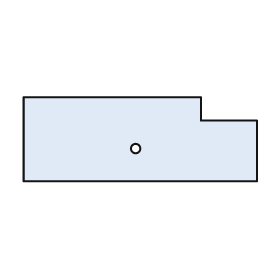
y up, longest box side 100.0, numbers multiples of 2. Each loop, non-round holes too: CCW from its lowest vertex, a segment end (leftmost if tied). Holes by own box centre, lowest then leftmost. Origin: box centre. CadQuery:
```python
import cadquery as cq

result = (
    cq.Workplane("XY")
    .moveTo(-50.0, -18.0)
    .lineTo(50.0, -18.0)
    .lineTo(50.0, 8.0)
    .lineTo(26.0, 8.0)
    .lineTo(26.0, 18.0)
    .lineTo(-50.0, 18.0)
    .close()
    .moveTo(-2.0, -4.0)
    .circle(2.0)
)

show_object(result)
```